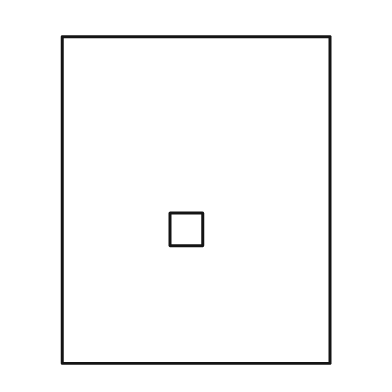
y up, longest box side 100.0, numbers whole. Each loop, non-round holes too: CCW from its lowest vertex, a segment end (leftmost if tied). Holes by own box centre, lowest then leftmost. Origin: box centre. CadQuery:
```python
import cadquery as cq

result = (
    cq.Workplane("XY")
    .moveTo(-41.0, -50.0)
    .lineTo(41.0, -50.0)
    .lineTo(41.0, 50.0)
    .lineTo(-41.0, 50.0)
    .close()
    .moveTo(-8.0, -14.0)
    .lineTo(2.0, -14.0)
    .lineTo(2.0, -4.0)
    .lineTo(-8.0, -4.0)
    .close()
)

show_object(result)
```